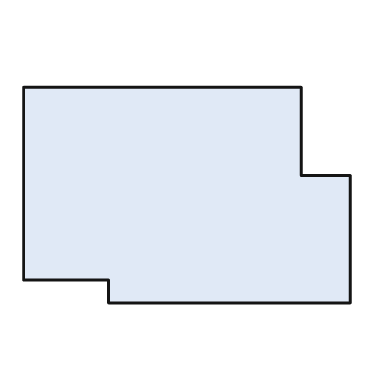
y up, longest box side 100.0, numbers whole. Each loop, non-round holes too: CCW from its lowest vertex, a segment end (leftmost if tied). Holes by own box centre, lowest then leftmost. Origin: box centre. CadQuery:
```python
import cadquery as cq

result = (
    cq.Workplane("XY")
    .moveTo(-24.0, -33.0)
    .lineTo(50.0, -33.0)
    .lineTo(50.0, 6.0)
    .lineTo(35.0, 6.0)
    .lineTo(35.0, 33.0)
    .lineTo(-50.0, 33.0)
    .lineTo(-50.0, -26.0)
    .lineTo(-24.0, -26.0)
    .close()
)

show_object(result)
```